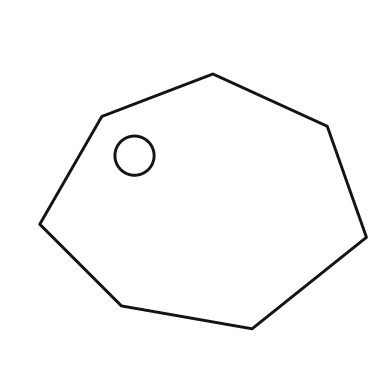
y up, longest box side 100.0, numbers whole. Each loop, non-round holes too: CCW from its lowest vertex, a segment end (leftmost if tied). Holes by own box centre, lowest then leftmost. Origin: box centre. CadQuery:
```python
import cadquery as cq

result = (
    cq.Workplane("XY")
    .moveTo(15.0, -39.0)
    .lineTo(50.0, -11.0)
    .lineTo(38.0, 23.0)
    .lineTo(3.0, 39.0)
    .lineTo(-31.0, 26.0)
    .lineTo(-50.0, -7.0)
    .lineTo(-25.0, -32.0)
    .close()
    .moveTo(-21.0, 14.0)
    .circle(6.0)
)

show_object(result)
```